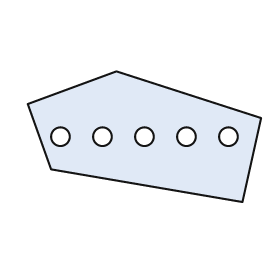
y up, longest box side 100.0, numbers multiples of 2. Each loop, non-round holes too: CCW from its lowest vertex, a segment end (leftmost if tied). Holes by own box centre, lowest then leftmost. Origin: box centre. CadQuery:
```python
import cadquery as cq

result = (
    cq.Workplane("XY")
    .moveTo(42.0, -28.0)
    .lineTo(50.0, 8.0)
    .lineTo(-12.0, 28.0)
    .lineTo(-50.0, 14.0)
    .lineTo(-40.0, -14.0)
    .close()
    .moveTo(-36.0, 0.0)
    .circle(4.0)
    .moveTo(-18.0, 0.0)
    .circle(4.0)
    .moveTo(0.0, 0.0)
    .circle(4.0)
    .moveTo(18.0, 0.0)
    .circle(4.0)
    .moveTo(36.0, 0.0)
    .circle(4.0)
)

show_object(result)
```